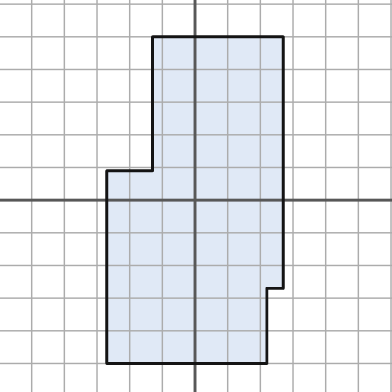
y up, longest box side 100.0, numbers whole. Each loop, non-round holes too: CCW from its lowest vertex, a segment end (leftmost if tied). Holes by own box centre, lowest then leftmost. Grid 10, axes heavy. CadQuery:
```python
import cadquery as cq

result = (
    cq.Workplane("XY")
    .moveTo(-27.0, -50.0)
    .lineTo(22.0, -50.0)
    .lineTo(22.0, -27.0)
    .lineTo(27.0, -27.0)
    .lineTo(27.0, 50.0)
    .lineTo(-13.0, 50.0)
    .lineTo(-13.0, 9.0)
    .lineTo(-27.0, 9.0)
    .close()
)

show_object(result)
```